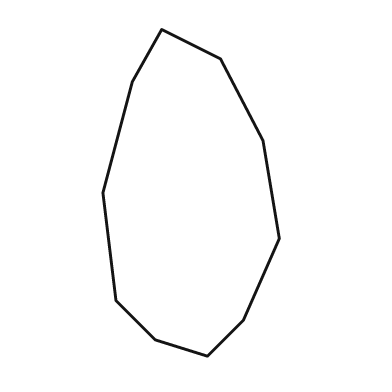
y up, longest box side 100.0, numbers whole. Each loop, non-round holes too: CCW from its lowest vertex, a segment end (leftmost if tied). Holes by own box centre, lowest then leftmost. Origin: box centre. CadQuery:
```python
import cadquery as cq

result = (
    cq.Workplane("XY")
    .moveTo(5.0, -50.0)
    .lineTo(16.0, -39.0)
    .lineTo(27.0, -14.0)
    .lineTo(22.0, 16.0)
    .lineTo(9.0, 41.0)
    .lineTo(-9.0, 50.0)
    .lineTo(-18.0, 34.0)
    .lineTo(-27.0, 0.0)
    .lineTo(-23.0, -33.0)
    .lineTo(-11.0, -45.0)
    .close()
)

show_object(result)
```